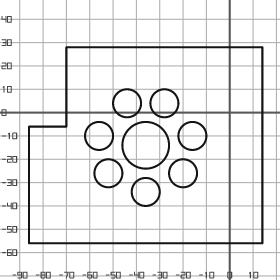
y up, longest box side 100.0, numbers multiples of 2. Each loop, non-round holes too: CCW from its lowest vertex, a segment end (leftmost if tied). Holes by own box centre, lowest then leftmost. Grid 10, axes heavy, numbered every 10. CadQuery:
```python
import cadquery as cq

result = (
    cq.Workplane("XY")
    .moveTo(-86.0, -56.0)
    .lineTo(14.0, -56.0)
    .lineTo(14.0, 28.0)
    .lineTo(-70.0, 28.0)
    .lineTo(-70.0, -6.0)
    .lineTo(-86.0, -6.0)
    .close()
    .moveTo(-36.0, -34.0)
    .circle(6.0)
    .moveTo(-52.0, -26.0)
    .circle(6.0)
    .moveTo(-20.0, -26.0)
    .circle(6.0)
    .moveTo(-36.0, -14.0)
    .circle(10.0)
    .moveTo(-56.0, -10.0)
    .circle(6.0)
    .moveTo(-16.0, -10.0)
    .circle(6.0)
    .moveTo(-44.0, 4.0)
    .circle(6.0)
    .moveTo(-28.0, 4.0)
    .circle(6.0)
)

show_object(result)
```